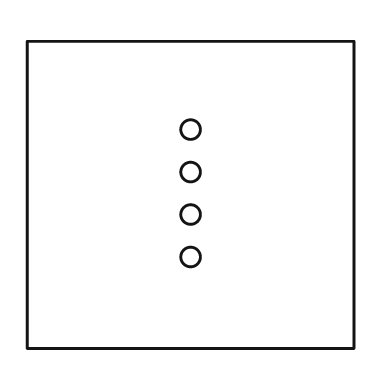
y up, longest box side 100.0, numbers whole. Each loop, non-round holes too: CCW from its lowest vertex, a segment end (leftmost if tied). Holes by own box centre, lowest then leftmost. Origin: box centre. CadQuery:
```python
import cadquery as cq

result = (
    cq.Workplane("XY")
    .moveTo(-50.0, -47.0)
    .lineTo(50.0, -47.0)
    .lineTo(50.0, 47.0)
    .lineTo(-50.0, 47.0)
    .close()
    .moveTo(0.0, -19.0)
    .circle(3.0)
    .moveTo(0.0, -6.0)
    .circle(3.0)
    .moveTo(0.0, 7.0)
    .circle(3.0)
    .moveTo(0.0, 20.0)
    .circle(3.0)
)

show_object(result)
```